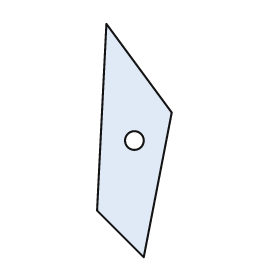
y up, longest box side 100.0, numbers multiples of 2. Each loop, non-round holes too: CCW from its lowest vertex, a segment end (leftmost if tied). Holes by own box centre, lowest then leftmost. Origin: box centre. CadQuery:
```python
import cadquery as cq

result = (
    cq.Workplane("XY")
    .moveTo(4.0, -50.0)
    .lineTo(16.0, 12.0)
    .lineTo(-12.0, 50.0)
    .lineTo(-16.0, -30.0)
    .close()
    .moveTo(0.0, 0.0)
    .circle(4.0)
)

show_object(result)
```